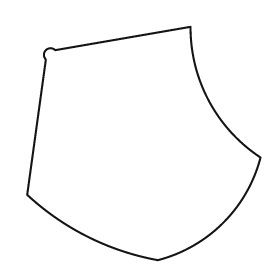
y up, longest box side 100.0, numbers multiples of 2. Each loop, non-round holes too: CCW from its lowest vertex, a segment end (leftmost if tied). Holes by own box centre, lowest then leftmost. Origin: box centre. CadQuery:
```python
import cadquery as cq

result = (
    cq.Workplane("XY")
    .moveTo(6.0, -50.0)
    .threePointArc((34.0, -34.0), (50.0, -6.0))
    .threePointArc((28.0, 18.0), (20.0, 50.0))
    .lineTo(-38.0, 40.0)
    .threePointArc((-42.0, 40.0), (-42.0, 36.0))
    .lineTo(-50.0, -22.0)
    .threePointArc((-24.0, -40.0), (6.0, -50.0))
    .close()
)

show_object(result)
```